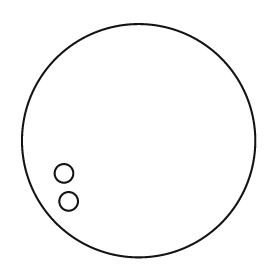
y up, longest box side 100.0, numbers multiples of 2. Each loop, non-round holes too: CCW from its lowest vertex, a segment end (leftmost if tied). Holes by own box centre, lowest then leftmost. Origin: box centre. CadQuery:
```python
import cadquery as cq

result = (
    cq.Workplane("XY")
    .moveTo(0.0, 0.0)
    .circle(50.0)
    .moveTo(-30.0, -26.0)
    .circle(4.0)
    .moveTo(-32.0, -14.0)
    .circle(4.0)
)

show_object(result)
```